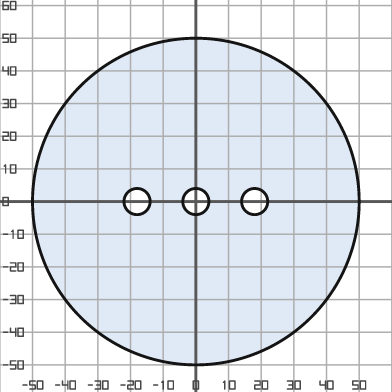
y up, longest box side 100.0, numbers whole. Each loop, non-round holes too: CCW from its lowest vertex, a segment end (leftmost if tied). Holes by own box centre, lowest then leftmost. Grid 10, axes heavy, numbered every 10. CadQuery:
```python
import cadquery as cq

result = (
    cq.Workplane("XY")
    .moveTo(0.0, 0.0)
    .circle(50.0)
    .moveTo(-18.0, 0.0)
    .circle(4.0)
    .moveTo(0.0, 0.0)
    .circle(4.0)
    .moveTo(18.0, 0.0)
    .circle(4.0)
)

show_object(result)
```